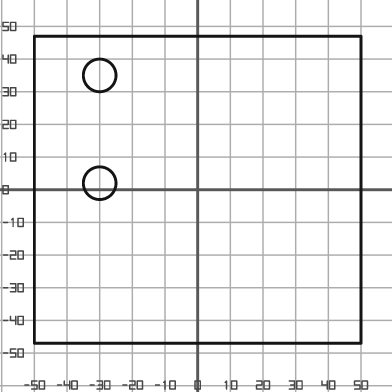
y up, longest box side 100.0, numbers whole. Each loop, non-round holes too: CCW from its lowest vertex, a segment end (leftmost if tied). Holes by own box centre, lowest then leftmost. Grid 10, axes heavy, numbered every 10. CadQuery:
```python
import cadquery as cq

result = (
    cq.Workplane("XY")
    .moveTo(-50.0, -47.0)
    .lineTo(50.0, -47.0)
    .lineTo(50.0, 47.0)
    .lineTo(-50.0, 47.0)
    .close()
    .moveTo(-30.0, 2.0)
    .circle(5.0)
    .moveTo(-30.0, 35.0)
    .circle(5.0)
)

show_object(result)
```